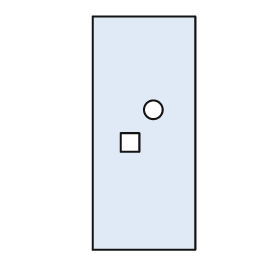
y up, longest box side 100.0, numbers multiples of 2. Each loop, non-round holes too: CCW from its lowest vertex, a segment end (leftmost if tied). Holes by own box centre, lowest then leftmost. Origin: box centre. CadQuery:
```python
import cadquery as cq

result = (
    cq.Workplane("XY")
    .moveTo(-22.0, -50.0)
    .lineTo(22.0, -50.0)
    .lineTo(22.0, 50.0)
    .lineTo(-22.0, 50.0)
    .close()
    .moveTo(-10.0, -8.0)
    .lineTo(-2.0, -8.0)
    .lineTo(-2.0, 0.0)
    .lineTo(-10.0, 0.0)
    .close()
    .moveTo(4.0, 10.0)
    .circle(4.0)
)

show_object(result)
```